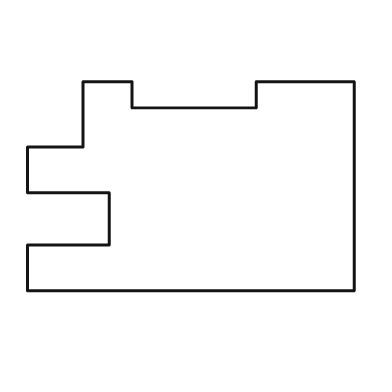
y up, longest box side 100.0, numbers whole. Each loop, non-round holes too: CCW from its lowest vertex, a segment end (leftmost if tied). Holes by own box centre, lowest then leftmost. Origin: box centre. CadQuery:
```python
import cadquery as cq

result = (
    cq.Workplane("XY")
    .moveTo(-50.0, -32.0)
    .lineTo(50.0, -32.0)
    .lineTo(50.0, 32.0)
    .lineTo(20.0, 32.0)
    .lineTo(20.0, 24.0)
    .lineTo(-18.0, 24.0)
    .lineTo(-18.0, 32.0)
    .lineTo(-33.0, 32.0)
    .lineTo(-33.0, 12.0)
    .lineTo(-50.0, 12.0)
    .lineTo(-50.0, -2.0)
    .lineTo(-25.0, -2.0)
    .lineTo(-25.0, -18.0)
    .lineTo(-50.0, -18.0)
    .close()
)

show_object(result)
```